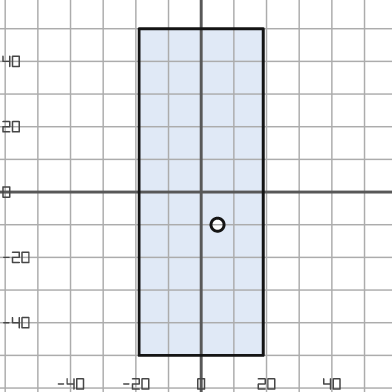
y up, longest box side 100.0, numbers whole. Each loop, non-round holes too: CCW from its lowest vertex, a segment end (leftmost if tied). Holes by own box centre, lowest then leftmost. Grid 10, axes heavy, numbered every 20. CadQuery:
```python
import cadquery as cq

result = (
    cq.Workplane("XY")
    .moveTo(-19.0, -50.0)
    .lineTo(19.0, -50.0)
    .lineTo(19.0, 50.0)
    .lineTo(-19.0, 50.0)
    .close()
    .moveTo(5.0, -10.0)
    .circle(2.0)
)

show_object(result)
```